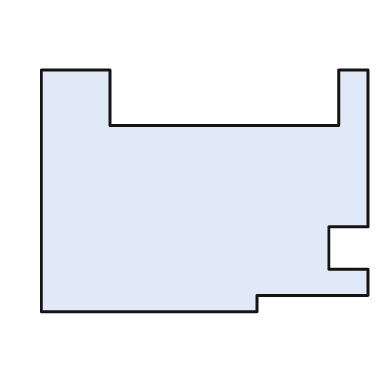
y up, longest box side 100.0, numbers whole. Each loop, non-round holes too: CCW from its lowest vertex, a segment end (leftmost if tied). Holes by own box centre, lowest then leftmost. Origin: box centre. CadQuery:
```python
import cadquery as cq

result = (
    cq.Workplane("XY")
    .moveTo(-50.0, -37.0)
    .lineTo(16.0, -37.0)
    .lineTo(16.0, -32.0)
    .lineTo(50.0, -32.0)
    .lineTo(50.0, -24.0)
    .lineTo(38.0, -24.0)
    .lineTo(38.0, -11.0)
    .lineTo(50.0, -11.0)
    .lineTo(50.0, 37.0)
    .lineTo(41.0, 37.0)
    .lineTo(41.0, 20.0)
    .lineTo(-29.0, 20.0)
    .lineTo(-29.0, 37.0)
    .lineTo(-50.0, 37.0)
    .close()
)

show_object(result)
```